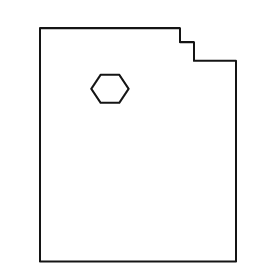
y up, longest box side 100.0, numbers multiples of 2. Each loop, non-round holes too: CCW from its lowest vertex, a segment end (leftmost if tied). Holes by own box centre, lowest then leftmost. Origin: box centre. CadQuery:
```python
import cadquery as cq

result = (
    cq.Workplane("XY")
    .moveTo(-42.0, -50.0)
    .lineTo(42.0, -50.0)
    .lineTo(42.0, 36.0)
    .lineTo(24.0, 36.0)
    .lineTo(24.0, 44.0)
    .lineTo(18.0, 44.0)
    .lineTo(18.0, 50.0)
    .lineTo(-42.0, 50.0)
    .close()
    .moveTo(-16.0, 18.0)
    .lineTo(-8.0, 18.0)
    .lineTo(-4.0, 24.0)
    .lineTo(-8.0, 30.0)
    .lineTo(-16.0, 30.0)
    .lineTo(-20.0, 24.0)
    .close()
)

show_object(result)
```